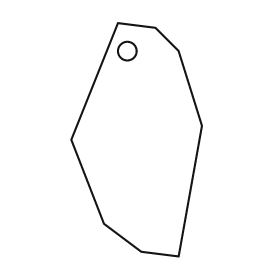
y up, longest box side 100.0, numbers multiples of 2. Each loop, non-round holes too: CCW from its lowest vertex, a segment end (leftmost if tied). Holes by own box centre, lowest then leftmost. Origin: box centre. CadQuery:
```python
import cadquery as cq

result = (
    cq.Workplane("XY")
    .moveTo(18.0, -50.0)
    .lineTo(28.0, 6.0)
    .lineTo(18.0, 38.0)
    .lineTo(8.0, 48.0)
    .lineTo(-8.0, 50.0)
    .lineTo(-28.0, 0.0)
    .lineTo(-14.0, -36.0)
    .lineTo(2.0, -48.0)
    .close()
    .moveTo(-4.0, 38.0)
    .circle(4.0)
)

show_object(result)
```